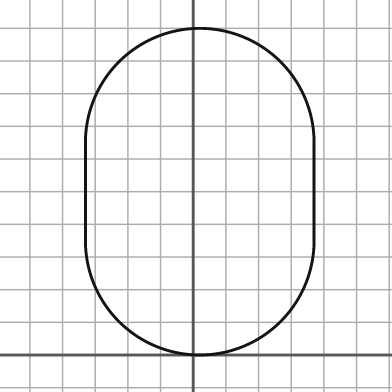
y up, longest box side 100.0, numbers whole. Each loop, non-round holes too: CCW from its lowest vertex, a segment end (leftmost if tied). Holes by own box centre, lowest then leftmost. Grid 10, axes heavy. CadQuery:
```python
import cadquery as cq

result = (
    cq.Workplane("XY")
    .moveTo(-33.0, 35.0)
    .threePointArc((2.0, 0.0), (37.0, 35.0))
    .lineTo(37.0, 65.0)
    .threePointArc((2.0, 100.0), (-33.0, 65.0))
    .close()
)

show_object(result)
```